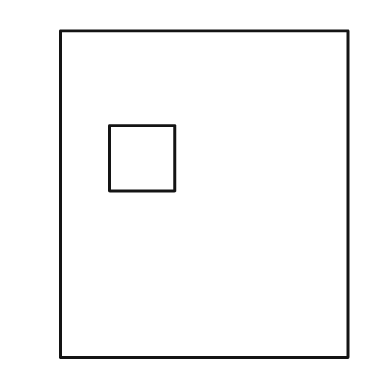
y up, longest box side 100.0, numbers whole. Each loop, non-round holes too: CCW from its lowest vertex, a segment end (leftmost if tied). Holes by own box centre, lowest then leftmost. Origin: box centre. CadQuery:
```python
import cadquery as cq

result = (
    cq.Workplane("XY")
    .moveTo(-44.0, -50.0)
    .lineTo(44.0, -50.0)
    .lineTo(44.0, 50.0)
    .lineTo(-44.0, 50.0)
    .close()
    .moveTo(-29.0, 1.0)
    .lineTo(-9.0, 1.0)
    .lineTo(-9.0, 21.0)
    .lineTo(-29.0, 21.0)
    .close()
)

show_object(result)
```